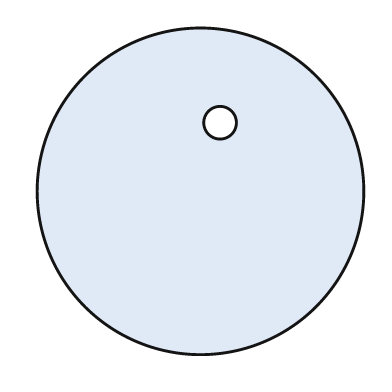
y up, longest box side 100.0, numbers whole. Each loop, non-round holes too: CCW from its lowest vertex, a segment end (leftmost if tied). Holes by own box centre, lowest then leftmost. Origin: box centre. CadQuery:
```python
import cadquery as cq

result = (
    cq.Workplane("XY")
    .moveTo(0.0, 0.0)
    .circle(50.0)
    .moveTo(6.0, 21.0)
    .circle(5.0)
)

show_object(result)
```